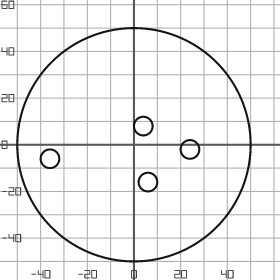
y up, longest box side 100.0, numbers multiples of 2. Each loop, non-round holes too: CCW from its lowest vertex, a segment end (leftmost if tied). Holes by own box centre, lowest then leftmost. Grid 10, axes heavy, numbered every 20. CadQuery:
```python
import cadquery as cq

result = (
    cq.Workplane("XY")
    .moveTo(0.0, 0.0)
    .circle(50.0)
    .moveTo(6.0, -16.0)
    .circle(4.0)
    .moveTo(-36.0, -6.0)
    .circle(4.0)
    .moveTo(24.0, -2.0)
    .circle(4.0)
    .moveTo(4.0, 8.0)
    .circle(4.0)
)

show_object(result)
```